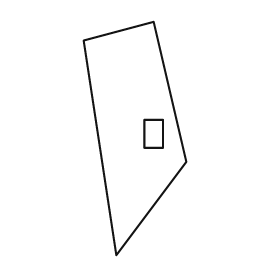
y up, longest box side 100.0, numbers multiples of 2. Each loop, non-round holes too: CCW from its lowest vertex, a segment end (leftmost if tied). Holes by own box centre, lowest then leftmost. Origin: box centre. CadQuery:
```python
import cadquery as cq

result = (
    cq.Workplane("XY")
    .moveTo(-8.0, -50.0)
    .lineTo(22.0, -10.0)
    .lineTo(8.0, 50.0)
    .lineTo(-22.0, 42.0)
    .close()
    .moveTo(4.0, -4.0)
    .lineTo(12.0, -4.0)
    .lineTo(12.0, 8.0)
    .lineTo(4.0, 8.0)
    .close()
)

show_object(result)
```